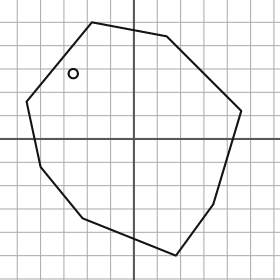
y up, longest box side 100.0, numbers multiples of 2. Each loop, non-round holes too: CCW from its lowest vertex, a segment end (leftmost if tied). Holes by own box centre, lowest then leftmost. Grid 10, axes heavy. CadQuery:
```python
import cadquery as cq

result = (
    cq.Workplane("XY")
    .moveTo(18.0, -50.0)
    .lineTo(34.0, -28.0)
    .lineTo(46.0, 12.0)
    .lineTo(14.0, 44.0)
    .lineTo(-18.0, 50.0)
    .lineTo(-46.0, 16.0)
    .lineTo(-40.0, -12.0)
    .lineTo(-22.0, -34.0)
    .close()
    .moveTo(-26.0, 28.0)
    .circle(2.0)
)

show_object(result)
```